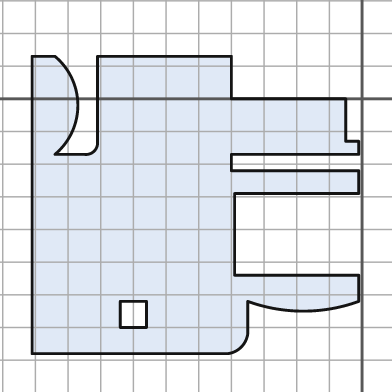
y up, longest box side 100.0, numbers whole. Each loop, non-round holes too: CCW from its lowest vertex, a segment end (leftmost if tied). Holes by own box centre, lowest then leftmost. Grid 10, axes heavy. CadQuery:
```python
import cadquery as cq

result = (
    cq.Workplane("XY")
    .moveTo(-101.0, -78.0)
    .lineTo(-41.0, -78.0)
    .threePointArc((-37.0, -76.0), (-35.0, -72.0))
    .lineTo(-35.0, -62.0)
    .threePointArc((-18.0, -65.0), (-1.0, -62.0))
    .lineTo(-1.0, -54.0)
    .lineTo(-39.0, -54.0)
    .lineTo(-39.0, -29.0)
    .lineTo(-1.0, -29.0)
    .lineTo(-1.0, -22.0)
    .lineTo(-40.0, -22.0)
    .lineTo(-40.0, -17.0)
    .lineTo(-1.0, -17.0)
    .lineTo(-1.0, -13.0)
    .lineTo(-5.0, -13.0)
    .lineTo(-5.0, 0.0)
    .lineTo(-40.0, 0.0)
    .lineTo(-40.0, 13.0)
    .lineTo(-81.0, 13.0)
    .lineTo(-81.0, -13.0)
    .threePointArc((-82.0, -16.0), (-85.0, -17.0))
    .lineTo(-94.0, -17.0)
    .threePointArc((-87.0, -2.0), (-94.0, 13.0))
    .lineTo(-101.0, 13.0)
    .close()
    .moveTo(-74.0, -70.0)
    .lineTo(-66.0, -70.0)
    .lineTo(-66.0, -62.0)
    .lineTo(-74.0, -62.0)
    .close()
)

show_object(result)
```